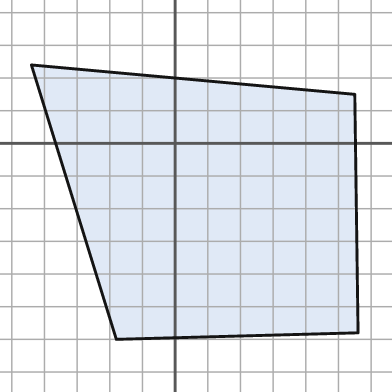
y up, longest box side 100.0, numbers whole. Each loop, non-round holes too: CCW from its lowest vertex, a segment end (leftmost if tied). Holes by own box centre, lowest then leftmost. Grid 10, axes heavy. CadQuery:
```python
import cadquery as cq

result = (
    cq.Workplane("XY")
    .moveTo(-18.0, -60.0)
    .lineTo(56.0, -58.0)
    .lineTo(55.0, 15.0)
    .lineTo(-44.0, 24.0)
    .close()
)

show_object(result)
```